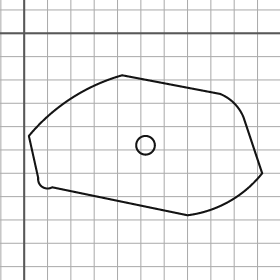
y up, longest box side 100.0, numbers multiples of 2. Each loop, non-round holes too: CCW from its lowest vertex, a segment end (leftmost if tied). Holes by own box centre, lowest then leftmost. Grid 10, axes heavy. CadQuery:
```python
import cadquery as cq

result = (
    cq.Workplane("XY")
    .moveTo(70.0, -78.0)
    .threePointArc((88.0, -72.0), (102.0, -60.0))
    .lineTo(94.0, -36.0)
    .threePointArc((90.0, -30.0), (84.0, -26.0))
    .lineTo(42.0, -18.0)
    .threePointArc((20.0, -28.0), (2.0, -44.0))
    .lineTo(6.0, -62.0)
    .threePointArc((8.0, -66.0), (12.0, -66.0))
    .close()
    .moveTo(52.0, -48.0)
    .circle(4.0)
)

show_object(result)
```